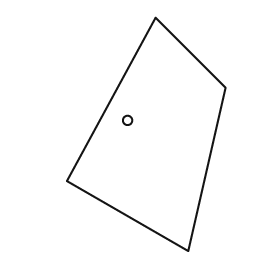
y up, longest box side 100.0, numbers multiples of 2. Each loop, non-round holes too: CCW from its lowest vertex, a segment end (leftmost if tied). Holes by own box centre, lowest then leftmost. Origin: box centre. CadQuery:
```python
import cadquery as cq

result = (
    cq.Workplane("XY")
    .moveTo(18.0, -50.0)
    .lineTo(34.0, 20.0)
    .lineTo(4.0, 50.0)
    .lineTo(-34.0, -20.0)
    .close()
    .moveTo(-8.0, 6.0)
    .circle(2.0)
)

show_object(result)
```